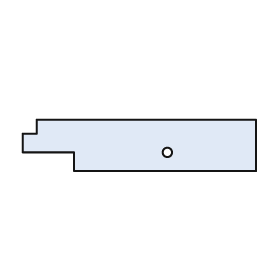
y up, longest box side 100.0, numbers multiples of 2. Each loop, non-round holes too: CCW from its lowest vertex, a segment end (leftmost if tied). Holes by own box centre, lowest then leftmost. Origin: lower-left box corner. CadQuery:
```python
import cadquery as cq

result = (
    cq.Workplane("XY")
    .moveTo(22.0, 0.0)
    .lineTo(100.0, 0.0)
    .lineTo(100.0, 22.0)
    .lineTo(6.0, 22.0)
    .lineTo(6.0, 16.0)
    .lineTo(0.0, 16.0)
    .lineTo(0.0, 8.0)
    .lineTo(22.0, 8.0)
    .close()
    .moveTo(62.0, 8.0)
    .circle(2.0)
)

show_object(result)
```